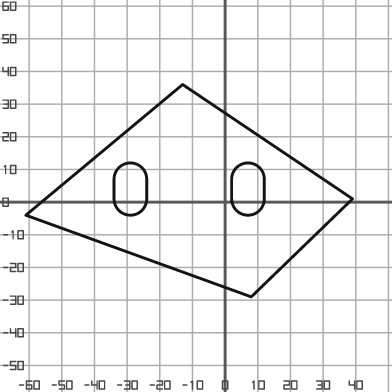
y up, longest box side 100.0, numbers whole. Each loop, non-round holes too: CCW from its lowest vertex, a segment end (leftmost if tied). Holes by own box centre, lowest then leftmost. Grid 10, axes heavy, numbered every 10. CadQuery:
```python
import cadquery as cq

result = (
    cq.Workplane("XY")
    .moveTo(8.0, -29.0)
    .lineTo(39.0, 1.0)
    .lineTo(-13.0, 36.0)
    .lineTo(-61.0, -4.0)
    .close()
    .moveTo(-34.0, 1.0)
    .threePointArc((-29.0, -4.0), (-24.0, 1.0))
    .lineTo(-24.0, 7.0)
    .threePointArc((-29.0, 12.0), (-34.0, 7.0))
    .close()
    .moveTo(2.0, 1.0)
    .threePointArc((7.0, -4.0), (12.0, 1.0))
    .lineTo(12.0, 7.0)
    .threePointArc((7.0, 12.0), (2.0, 7.0))
    .close()
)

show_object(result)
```